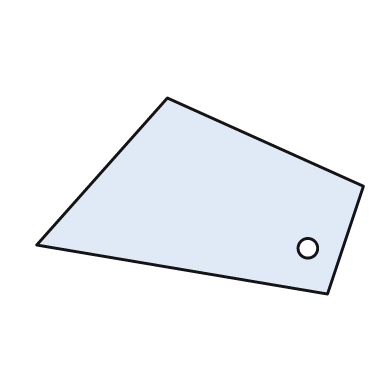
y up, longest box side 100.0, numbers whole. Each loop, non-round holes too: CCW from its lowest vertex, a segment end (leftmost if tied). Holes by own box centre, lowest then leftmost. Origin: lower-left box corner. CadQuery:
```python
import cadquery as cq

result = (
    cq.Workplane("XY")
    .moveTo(89.0, 0.0)
    .lineTo(100.0, 33.0)
    .lineTo(40.0, 60.0)
    .lineTo(0.0, 15.0)
    .close()
    .moveTo(83.0, 14.0)
    .circle(3.0)
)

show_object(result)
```